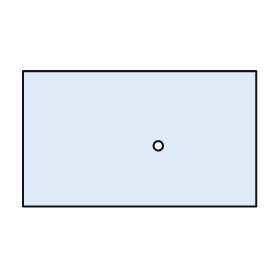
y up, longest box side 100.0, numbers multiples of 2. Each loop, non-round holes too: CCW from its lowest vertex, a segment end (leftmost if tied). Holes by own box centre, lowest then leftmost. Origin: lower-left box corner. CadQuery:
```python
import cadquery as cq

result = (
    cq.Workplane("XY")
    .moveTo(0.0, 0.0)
    .lineTo(100.0, 0.0)
    .lineTo(100.0, 58.0)
    .lineTo(0.0, 58.0)
    .close()
    .moveTo(58.0, 26.0)
    .circle(2.0)
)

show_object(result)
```